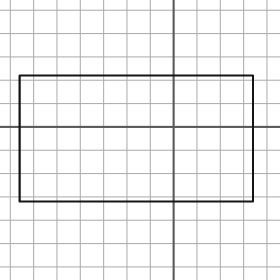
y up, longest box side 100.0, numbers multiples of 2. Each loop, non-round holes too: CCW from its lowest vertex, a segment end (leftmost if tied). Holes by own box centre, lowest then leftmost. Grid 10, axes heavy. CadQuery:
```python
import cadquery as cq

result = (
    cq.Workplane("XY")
    .moveTo(-66.0, -32.0)
    .lineTo(34.0, -32.0)
    .lineTo(34.0, 22.0)
    .lineTo(-66.0, 22.0)
    .close()
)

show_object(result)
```